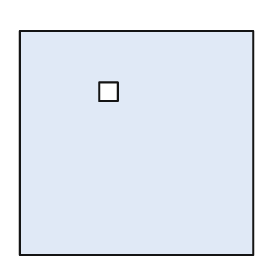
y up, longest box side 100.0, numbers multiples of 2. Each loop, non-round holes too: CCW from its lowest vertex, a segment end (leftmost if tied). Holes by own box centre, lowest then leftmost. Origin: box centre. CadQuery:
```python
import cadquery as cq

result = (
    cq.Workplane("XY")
    .moveTo(-50.0, -48.0)
    .lineTo(50.0, -48.0)
    .lineTo(50.0, 48.0)
    .lineTo(-50.0, 48.0)
    .close()
    .moveTo(-16.0, 18.0)
    .lineTo(-8.0, 18.0)
    .lineTo(-8.0, 26.0)
    .lineTo(-16.0, 26.0)
    .close()
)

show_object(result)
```